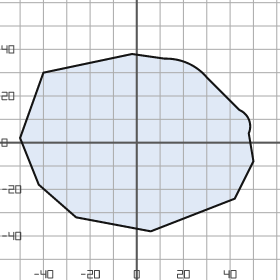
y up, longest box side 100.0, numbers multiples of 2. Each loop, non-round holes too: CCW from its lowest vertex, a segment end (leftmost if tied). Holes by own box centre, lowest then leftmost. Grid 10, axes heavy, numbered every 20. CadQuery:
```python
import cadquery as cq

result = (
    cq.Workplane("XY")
    .moveTo(6.0, -38.0)
    .lineTo(42.0, -24.0)
    .lineTo(50.0, -8.0)
    .lineTo(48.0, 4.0)
    .threePointArc((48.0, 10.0), (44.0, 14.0))
    .lineTo(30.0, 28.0)
    .threePointArc((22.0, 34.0), (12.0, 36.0))
    .lineTo(-2.0, 38.0)
    .lineTo(-40.0, 30.0)
    .lineTo(-50.0, 2.0)
    .lineTo(-42.0, -18.0)
    .lineTo(-26.0, -32.0)
    .close()
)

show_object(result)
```